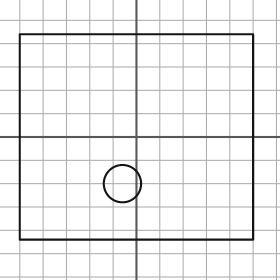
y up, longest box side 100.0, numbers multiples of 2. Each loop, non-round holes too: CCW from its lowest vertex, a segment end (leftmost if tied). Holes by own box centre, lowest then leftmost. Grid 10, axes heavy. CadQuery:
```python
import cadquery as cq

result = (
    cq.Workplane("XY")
    .moveTo(-50.0, -44.0)
    .lineTo(50.0, -44.0)
    .lineTo(50.0, 44.0)
    .lineTo(-50.0, 44.0)
    .close()
    .moveTo(-6.0, -20.0)
    .circle(8.0)
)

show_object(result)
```